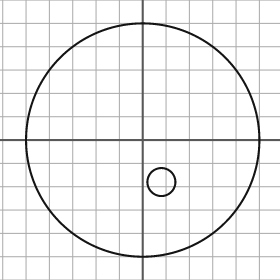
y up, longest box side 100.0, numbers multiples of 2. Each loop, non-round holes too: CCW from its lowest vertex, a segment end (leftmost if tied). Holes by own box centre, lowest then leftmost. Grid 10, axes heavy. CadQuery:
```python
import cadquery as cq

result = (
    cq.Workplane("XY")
    .moveTo(0.0, 0.0)
    .circle(50.0)
    .moveTo(8.0, -18.0)
    .circle(6.0)
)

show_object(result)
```